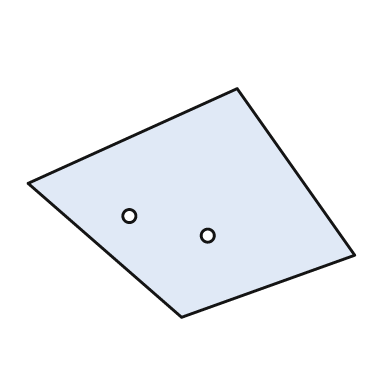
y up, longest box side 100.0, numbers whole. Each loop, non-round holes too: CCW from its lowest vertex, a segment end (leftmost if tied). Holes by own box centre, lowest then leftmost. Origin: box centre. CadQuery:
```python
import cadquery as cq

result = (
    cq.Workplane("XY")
    .moveTo(-3.0, -35.0)
    .lineTo(50.0, -16.0)
    .lineTo(14.0, 35.0)
    .lineTo(-50.0, 6.0)
    .close()
    .moveTo(5.0, -10.0)
    .circle(2.0)
    .moveTo(-19.0, -4.0)
    .circle(2.0)
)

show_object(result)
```